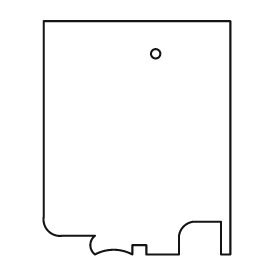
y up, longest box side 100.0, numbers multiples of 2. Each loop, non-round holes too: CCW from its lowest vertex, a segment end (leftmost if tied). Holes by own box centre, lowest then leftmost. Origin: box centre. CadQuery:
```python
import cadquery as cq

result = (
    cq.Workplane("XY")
    .moveTo(-18.0, -50.0)
    .threePointArc((-10.0, -48.0), (-2.0, -50.0))
    .lineTo(-2.0, -46.0)
    .lineTo(4.0, -46.0)
    .lineTo(4.0, -50.0)
    .lineTo(18.0, -50.0)
    .lineTo(18.0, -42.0)
    .threePointArc((20.0, -38.0), (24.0, -36.0))
    .lineTo(36.0, -36.0)
    .lineTo(36.0, -50.0)
    .lineTo(40.0, -50.0)
    .lineTo(40.0, 50.0)
    .lineTo(-40.0, 50.0)
    .lineTo(-40.0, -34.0)
    .threePointArc((-38.0, -40.0), (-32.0, -42.0))
    .lineTo(-18.0, -42.0)
    .threePointArc((-20.0, -46.0), (-18.0, -50.0))
    .close()
    .moveTo(8.0, 36.0)
    .circle(2.0)
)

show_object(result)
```